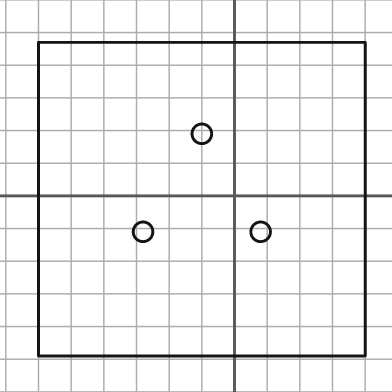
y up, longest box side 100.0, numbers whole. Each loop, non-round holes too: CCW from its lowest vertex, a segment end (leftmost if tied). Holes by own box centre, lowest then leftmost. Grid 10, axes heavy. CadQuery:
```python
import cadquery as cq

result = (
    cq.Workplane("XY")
    .moveTo(-60.0, -49.0)
    .lineTo(40.0, -49.0)
    .lineTo(40.0, 47.0)
    .lineTo(-60.0, 47.0)
    .close()
    .moveTo(-28.0, -11.0)
    .circle(3.0)
    .moveTo(8.0, -11.0)
    .circle(3.0)
    .moveTo(-10.0, 19.0)
    .circle(3.0)
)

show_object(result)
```